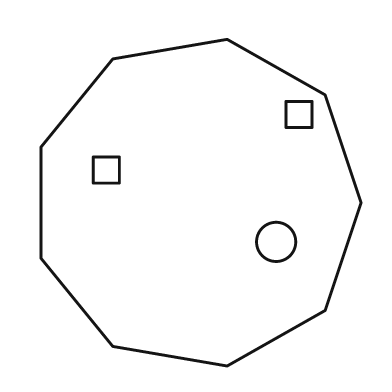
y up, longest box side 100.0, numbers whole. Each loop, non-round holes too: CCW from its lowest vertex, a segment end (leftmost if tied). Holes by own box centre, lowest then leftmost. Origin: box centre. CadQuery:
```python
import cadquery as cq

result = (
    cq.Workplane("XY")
    .moveTo(8.0, -50.0)
    .lineTo(38.0, -33.0)
    .lineTo(49.0, 0.0)
    .lineTo(38.0, 33.0)
    .lineTo(8.0, 50.0)
    .lineTo(-27.0, 44.0)
    .lineTo(-49.0, 17.0)
    .lineTo(-49.0, -17.0)
    .lineTo(-27.0, -44.0)
    .close()
    .moveTo(23.0, -12.0)
    .circle(6.0)
    .moveTo(-33.0, 6.0)
    .lineTo(-25.0, 6.0)
    .lineTo(-25.0, 14.0)
    .lineTo(-33.0, 14.0)
    .close()
    .moveTo(26.0, 23.0)
    .lineTo(34.0, 23.0)
    .lineTo(34.0, 31.0)
    .lineTo(26.0, 31.0)
    .close()
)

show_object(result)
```